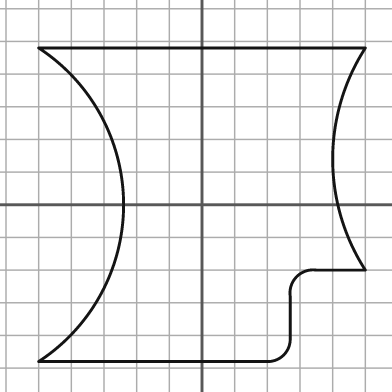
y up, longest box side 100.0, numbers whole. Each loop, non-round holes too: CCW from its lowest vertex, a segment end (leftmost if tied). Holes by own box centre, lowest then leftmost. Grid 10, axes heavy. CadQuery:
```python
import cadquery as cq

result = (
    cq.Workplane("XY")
    .moveTo(-50.0, -48.0)
    .lineTo(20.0, -48.0)
    .threePointArc((25.0, -46.0), (27.0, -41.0))
    .lineTo(27.0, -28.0)
    .threePointArc((29.0, -22.0), (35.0, -20.0))
    .lineTo(50.0, -20.0)
    .threePointArc((40.0, 14.0), (50.0, 48.0))
    .lineTo(-50.0, 48.0)
    .threePointArc((-24.0, 0.0), (-50.0, -48.0))
    .close()
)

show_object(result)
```